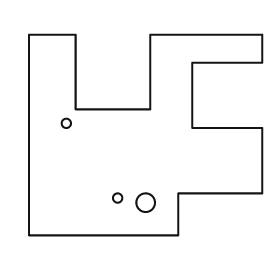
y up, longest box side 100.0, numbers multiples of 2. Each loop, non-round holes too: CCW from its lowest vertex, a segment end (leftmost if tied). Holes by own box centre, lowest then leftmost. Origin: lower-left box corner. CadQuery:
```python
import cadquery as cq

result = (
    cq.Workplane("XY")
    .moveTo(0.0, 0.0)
    .lineTo(64.0, 0.0)
    .lineTo(64.0, 18.0)
    .lineTo(100.0, 18.0)
    .lineTo(100.0, 46.0)
    .lineTo(70.0, 46.0)
    .lineTo(70.0, 74.0)
    .lineTo(100.0, 74.0)
    .lineTo(100.0, 86.0)
    .lineTo(52.0, 86.0)
    .lineTo(52.0, 54.0)
    .lineTo(20.0, 54.0)
    .lineTo(20.0, 86.0)
    .lineTo(0.0, 86.0)
    .close()
    .moveTo(50.0, 14.0)
    .circle(4.0)
    .moveTo(38.0, 16.0)
    .circle(2.0)
    .moveTo(16.0, 48.0)
    .circle(2.0)
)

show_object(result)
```